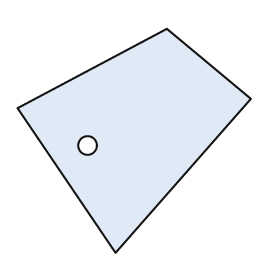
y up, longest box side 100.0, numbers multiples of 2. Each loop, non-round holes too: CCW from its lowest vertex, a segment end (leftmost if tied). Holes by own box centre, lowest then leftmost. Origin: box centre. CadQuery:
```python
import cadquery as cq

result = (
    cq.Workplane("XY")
    .moveTo(-8.0, -48.0)
    .lineTo(50.0, 18.0)
    .lineTo(14.0, 48.0)
    .lineTo(-50.0, 14.0)
    .close()
    .moveTo(-20.0, -2.0)
    .circle(4.0)
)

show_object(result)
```